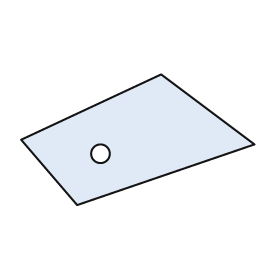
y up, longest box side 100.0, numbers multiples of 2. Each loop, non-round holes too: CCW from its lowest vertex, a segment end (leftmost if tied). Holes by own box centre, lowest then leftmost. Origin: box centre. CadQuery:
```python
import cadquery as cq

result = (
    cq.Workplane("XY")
    .moveTo(-26.0, -28.0)
    .lineTo(50.0, -2.0)
    .lineTo(10.0, 28.0)
    .lineTo(-50.0, 0.0)
    .close()
    .moveTo(-16.0, -6.0)
    .circle(4.0)
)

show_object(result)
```